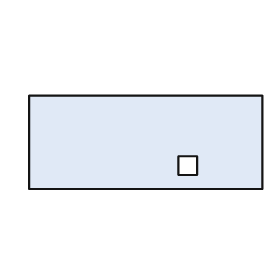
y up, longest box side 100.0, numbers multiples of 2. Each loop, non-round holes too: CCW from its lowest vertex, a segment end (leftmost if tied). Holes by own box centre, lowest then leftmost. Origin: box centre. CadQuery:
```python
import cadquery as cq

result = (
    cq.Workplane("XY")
    .moveTo(-50.0, -20.0)
    .lineTo(50.0, -20.0)
    .lineTo(50.0, 20.0)
    .lineTo(-50.0, 20.0)
    .close()
    .moveTo(14.0, -14.0)
    .lineTo(22.0, -14.0)
    .lineTo(22.0, -6.0)
    .lineTo(14.0, -6.0)
    .close()
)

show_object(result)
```